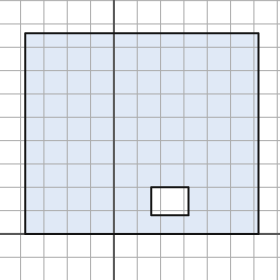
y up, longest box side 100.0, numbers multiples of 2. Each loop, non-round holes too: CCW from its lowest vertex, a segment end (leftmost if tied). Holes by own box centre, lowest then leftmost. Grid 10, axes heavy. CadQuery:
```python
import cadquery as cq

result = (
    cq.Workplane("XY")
    .moveTo(-38.0, 0.0)
    .lineTo(62.0, 0.0)
    .lineTo(62.0, 86.0)
    .lineTo(-38.0, 86.0)
    .close()
    .moveTo(16.0, 8.0)
    .lineTo(32.0, 8.0)
    .lineTo(32.0, 20.0)
    .lineTo(16.0, 20.0)
    .close()
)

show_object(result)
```